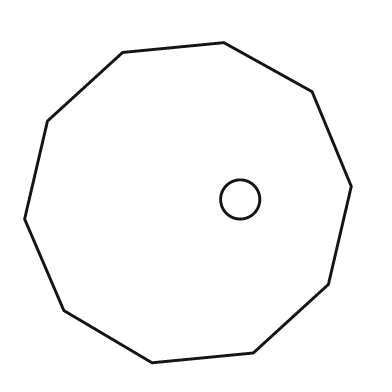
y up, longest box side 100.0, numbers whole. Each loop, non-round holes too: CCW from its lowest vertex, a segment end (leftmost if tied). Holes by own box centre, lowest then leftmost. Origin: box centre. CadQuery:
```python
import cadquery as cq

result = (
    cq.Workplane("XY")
    .moveTo(-11.0, -49.0)
    .lineTo(20.0, -46.0)
    .lineTo(43.0, -25.0)
    .lineTo(50.0, 5.0)
    .lineTo(38.0, 34.0)
    .lineTo(11.0, 49.0)
    .lineTo(-20.0, 46.0)
    .lineTo(-43.0, 25.0)
    .lineTo(-50.0, -5.0)
    .lineTo(-38.0, -33.0)
    .close()
    .moveTo(16.0, 1.0)
    .circle(6.0)
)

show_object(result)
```